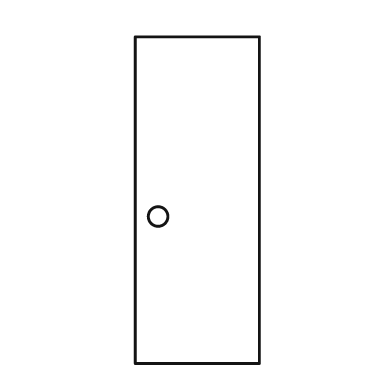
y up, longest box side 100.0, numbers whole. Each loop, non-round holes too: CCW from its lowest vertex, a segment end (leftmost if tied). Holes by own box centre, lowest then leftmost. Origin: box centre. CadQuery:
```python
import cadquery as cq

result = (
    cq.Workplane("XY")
    .moveTo(-19.0, -50.0)
    .lineTo(19.0, -50.0)
    .lineTo(19.0, 50.0)
    .lineTo(-19.0, 50.0)
    .close()
    .moveTo(-12.0, -5.0)
    .circle(3.0)
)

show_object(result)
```